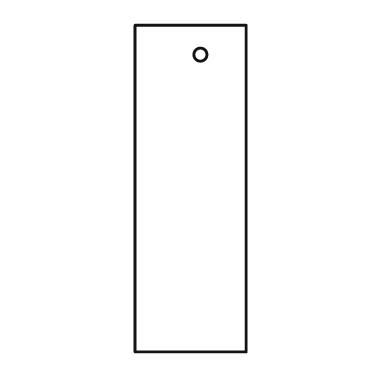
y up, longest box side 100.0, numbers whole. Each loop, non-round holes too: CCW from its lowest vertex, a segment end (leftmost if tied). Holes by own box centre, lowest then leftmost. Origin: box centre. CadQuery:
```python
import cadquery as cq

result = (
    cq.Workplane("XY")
    .moveTo(-17.0, -50.0)
    .lineTo(17.0, -50.0)
    .lineTo(17.0, 50.0)
    .lineTo(-17.0, 50.0)
    .close()
    .moveTo(3.0, 41.0)
    .circle(2.0)
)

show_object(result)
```